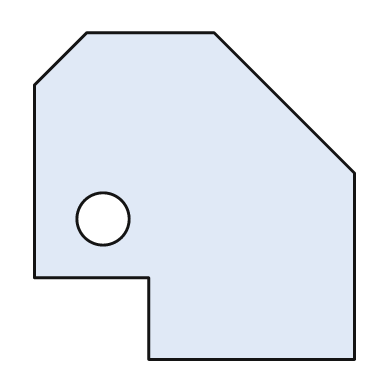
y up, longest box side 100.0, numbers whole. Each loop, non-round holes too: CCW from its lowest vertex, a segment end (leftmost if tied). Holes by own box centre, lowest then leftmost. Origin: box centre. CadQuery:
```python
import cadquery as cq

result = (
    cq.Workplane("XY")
    .moveTo(-14.0, -50.0)
    .lineTo(49.0, -50.0)
    .lineTo(49.0, 7.0)
    .lineTo(6.0, 50.0)
    .lineTo(-33.0, 50.0)
    .lineTo(-49.0, 34.0)
    .lineTo(-49.0, -25.0)
    .lineTo(-14.0, -25.0)
    .close()
    .moveTo(-28.0, -7.0)
    .circle(8.0)
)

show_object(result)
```